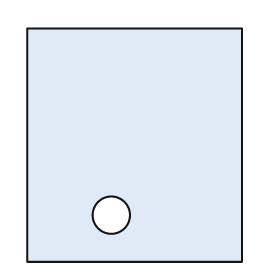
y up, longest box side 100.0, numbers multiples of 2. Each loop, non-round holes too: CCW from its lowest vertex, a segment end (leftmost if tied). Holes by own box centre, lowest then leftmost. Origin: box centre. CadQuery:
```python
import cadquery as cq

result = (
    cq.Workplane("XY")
    .moveTo(-46.0, -50.0)
    .lineTo(46.0, -50.0)
    .lineTo(46.0, 50.0)
    .lineTo(-46.0, 50.0)
    .close()
    .moveTo(-10.0, -30.0)
    .circle(8.0)
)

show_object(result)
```